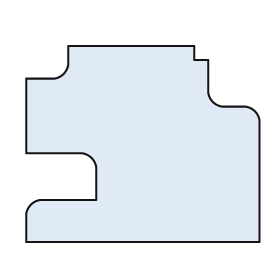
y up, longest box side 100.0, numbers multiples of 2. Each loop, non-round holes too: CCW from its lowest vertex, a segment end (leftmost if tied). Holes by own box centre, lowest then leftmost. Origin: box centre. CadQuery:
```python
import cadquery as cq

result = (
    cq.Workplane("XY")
    .moveTo(-50.0, -42.0)
    .lineTo(50.0, -42.0)
    .lineTo(50.0, 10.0)
    .threePointArc((48.0, 14.0), (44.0, 16.0))
    .lineTo(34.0, 16.0)
    .threePointArc((30.0, 18.0), (28.0, 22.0))
    .lineTo(28.0, 36.0)
    .lineTo(22.0, 36.0)
    .lineTo(22.0, 42.0)
    .lineTo(-32.0, 42.0)
    .lineTo(-32.0, 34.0)
    .threePointArc((-34.0, 30.0), (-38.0, 28.0))
    .lineTo(-50.0, 28.0)
    .lineTo(-50.0, -4.0)
    .lineTo(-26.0, -4.0)
    .threePointArc((-22.0, -6.0), (-20.0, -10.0))
    .lineTo(-20.0, -24.0)
    .lineTo(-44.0, -24.0)
    .threePointArc((-48.0, -26.0), (-50.0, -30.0))
    .close()
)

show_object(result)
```